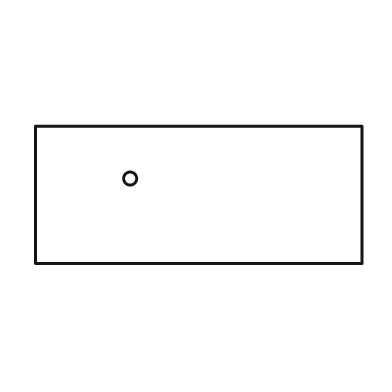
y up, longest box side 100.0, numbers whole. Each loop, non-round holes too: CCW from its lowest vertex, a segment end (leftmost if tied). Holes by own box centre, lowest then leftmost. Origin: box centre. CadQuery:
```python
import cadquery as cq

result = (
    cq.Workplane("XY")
    .moveTo(-50.0, -21.0)
    .lineTo(50.0, -21.0)
    .lineTo(50.0, 21.0)
    .lineTo(-50.0, 21.0)
    .close()
    .moveTo(-21.0, 5.0)
    .circle(2.0)
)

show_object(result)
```